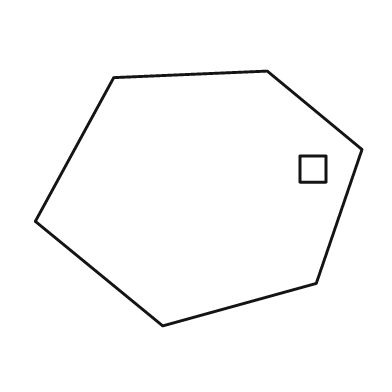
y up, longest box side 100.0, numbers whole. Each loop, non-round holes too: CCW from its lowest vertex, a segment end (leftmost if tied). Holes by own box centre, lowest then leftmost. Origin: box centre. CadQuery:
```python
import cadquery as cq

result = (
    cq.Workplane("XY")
    .moveTo(-11.0, -39.0)
    .lineTo(36.0, -26.0)
    .lineTo(50.0, 15.0)
    .lineTo(21.0, 39.0)
    .lineTo(-26.0, 37.0)
    .lineTo(-50.0, -7.0)
    .close()
    .moveTo(31.0, 5.0)
    .lineTo(39.0, 5.0)
    .lineTo(39.0, 13.0)
    .lineTo(31.0, 13.0)
    .close()
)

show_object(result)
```